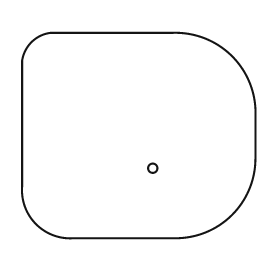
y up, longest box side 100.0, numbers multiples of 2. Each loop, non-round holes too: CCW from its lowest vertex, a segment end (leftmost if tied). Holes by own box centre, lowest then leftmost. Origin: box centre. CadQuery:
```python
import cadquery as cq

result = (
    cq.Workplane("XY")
    .moveTo(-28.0, -44.0)
    .lineTo(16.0, -44.0)
    .threePointArc((40.0, -34.0), (50.0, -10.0))
    .lineTo(50.0, 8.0)
    .threePointArc((40.0, 34.0), (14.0, 44.0))
    .lineTo(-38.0, 44.0)
    .threePointArc((-46.0, 40.0), (-50.0, 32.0))
    .lineTo(-50.0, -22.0)
    .threePointArc((-44.0, -38.0), (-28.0, -44.0))
    .close()
    .moveTo(6.0, -14.0)
    .circle(2.0)
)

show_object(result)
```